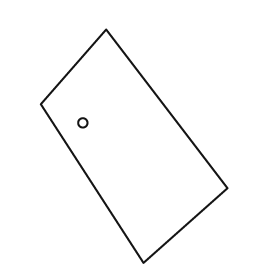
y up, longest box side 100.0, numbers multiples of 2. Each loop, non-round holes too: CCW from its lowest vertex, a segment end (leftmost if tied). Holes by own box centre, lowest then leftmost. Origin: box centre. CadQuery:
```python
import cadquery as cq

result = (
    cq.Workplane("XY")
    .moveTo(4.0, -50.0)
    .lineTo(40.0, -18.0)
    .lineTo(-12.0, 50.0)
    .lineTo(-40.0, 18.0)
    .close()
    .moveTo(-22.0, 10.0)
    .circle(2.0)
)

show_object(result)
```